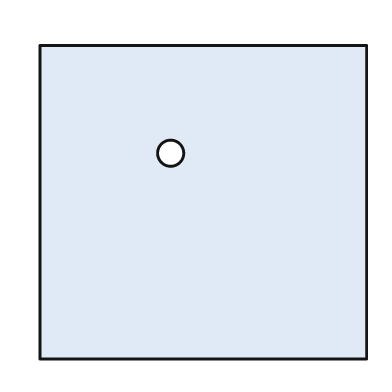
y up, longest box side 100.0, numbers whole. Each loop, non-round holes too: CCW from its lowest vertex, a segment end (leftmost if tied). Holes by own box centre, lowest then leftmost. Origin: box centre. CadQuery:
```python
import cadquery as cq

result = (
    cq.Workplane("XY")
    .moveTo(-50.0, -48.0)
    .lineTo(50.0, -48.0)
    .lineTo(50.0, 48.0)
    .lineTo(-50.0, 48.0)
    .close()
    .moveTo(-10.0, 15.0)
    .circle(4.0)
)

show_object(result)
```